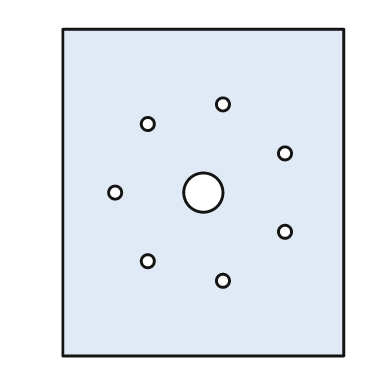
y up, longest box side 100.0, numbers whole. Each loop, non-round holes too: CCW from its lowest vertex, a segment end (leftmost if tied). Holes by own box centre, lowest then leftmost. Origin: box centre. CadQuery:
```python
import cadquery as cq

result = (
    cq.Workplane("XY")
    .moveTo(-43.0, -50.0)
    .lineTo(43.0, -50.0)
    .lineTo(43.0, 50.0)
    .lineTo(-43.0, 50.0)
    .close()
    .moveTo(6.0, -27.0)
    .circle(2.0)
    .moveTo(-17.0, -21.0)
    .circle(2.0)
    .moveTo(25.0, -12.0)
    .circle(2.0)
    .moveTo(-27.0, 0.0)
    .circle(2.0)
    .moveTo(0.0, 0.0)
    .circle(6.0)
    .moveTo(25.0, 12.0)
    .circle(2.0)
    .moveTo(-17.0, 21.0)
    .circle(2.0)
    .moveTo(6.0, 27.0)
    .circle(2.0)
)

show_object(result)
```